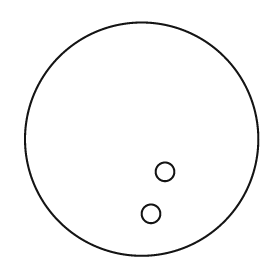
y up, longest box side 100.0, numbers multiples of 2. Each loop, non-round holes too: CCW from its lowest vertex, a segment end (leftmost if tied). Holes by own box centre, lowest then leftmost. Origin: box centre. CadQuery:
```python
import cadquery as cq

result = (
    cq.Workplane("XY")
    .moveTo(0.0, 0.0)
    .circle(50.0)
    .moveTo(4.0, -32.0)
    .circle(4.0)
    .moveTo(10.0, -14.0)
    .circle(4.0)
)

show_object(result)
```